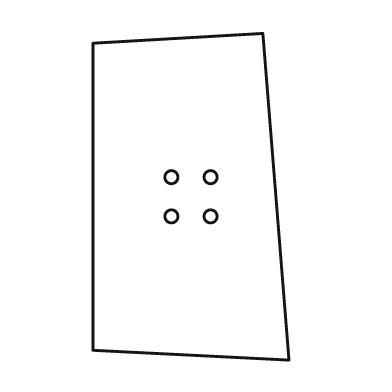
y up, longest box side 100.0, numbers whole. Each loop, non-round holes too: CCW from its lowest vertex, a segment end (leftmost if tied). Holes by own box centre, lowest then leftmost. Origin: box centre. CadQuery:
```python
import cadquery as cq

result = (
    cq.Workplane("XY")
    .moveTo(30.0, -50.0)
    .lineTo(22.0, 50.0)
    .lineTo(-30.0, 47.0)
    .lineTo(-30.0, -47.0)
    .close()
    .moveTo(-6.0, -6.0)
    .circle(2.0)
    .moveTo(6.0, -6.0)
    .circle(2.0)
    .moveTo(-6.0, 6.0)
    .circle(2.0)
    .moveTo(6.0, 6.0)
    .circle(2.0)
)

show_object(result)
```